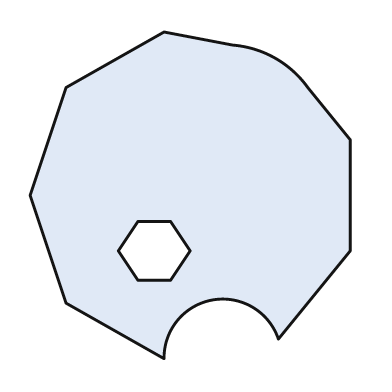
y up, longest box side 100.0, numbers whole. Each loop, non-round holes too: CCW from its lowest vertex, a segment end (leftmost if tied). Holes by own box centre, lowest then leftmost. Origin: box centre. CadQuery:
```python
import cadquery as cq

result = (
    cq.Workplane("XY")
    .moveTo(-8.0, -50.0)
    .threePointArc((7.0, -32.0), (27.0, -44.0))
    .lineTo(49.0, -17.0)
    .lineTo(49.0, 17.0)
    .lineTo(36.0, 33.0)
    .threePointArc((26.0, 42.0), (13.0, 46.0))
    .lineTo(-8.0, 50.0)
    .lineTo(-38.0, 33.0)
    .lineTo(-49.0, 0.0)
    .lineTo(-38.0, -33.0)
    .close()
    .moveTo(-16.0, -26.0)
    .lineTo(-6.0, -26.0)
    .lineTo(0.0, -17.0)
    .lineTo(-6.0, -8.0)
    .lineTo(-16.0, -8.0)
    .lineTo(-22.0, -17.0)
    .close()
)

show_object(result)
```